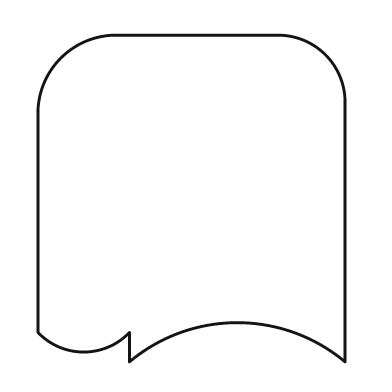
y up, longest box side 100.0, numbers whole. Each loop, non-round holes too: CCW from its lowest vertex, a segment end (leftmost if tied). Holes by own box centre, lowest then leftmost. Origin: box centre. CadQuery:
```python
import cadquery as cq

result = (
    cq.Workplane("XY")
    .moveTo(-19.0, -50.0)
    .threePointArc((14.0, -38.0), (47.0, -50.0))
    .lineTo(47.0, 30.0)
    .threePointArc((41.0, 44.0), (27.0, 50.0))
    .lineTo(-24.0, 50.0)
    .threePointArc((-40.0, 43.0), (-47.0, 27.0))
    .lineTo(-47.0, -41.0)
    .threePointArc((-33.0, -47.0), (-19.0, -41.0))
    .close()
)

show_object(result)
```